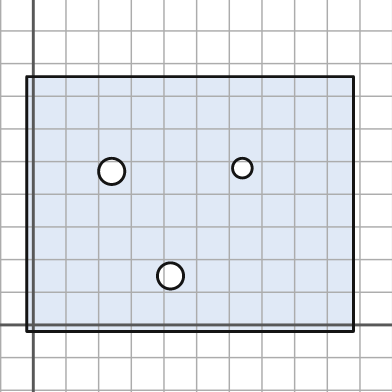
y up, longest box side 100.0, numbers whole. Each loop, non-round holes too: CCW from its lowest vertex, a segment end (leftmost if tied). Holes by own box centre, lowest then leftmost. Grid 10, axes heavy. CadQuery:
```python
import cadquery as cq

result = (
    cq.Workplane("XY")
    .moveTo(-2.0, -2.0)
    .lineTo(98.0, -2.0)
    .lineTo(98.0, 76.0)
    .lineTo(-2.0, 76.0)
    .close()
    .moveTo(42.0, 15.0)
    .circle(4.0)
    .moveTo(24.0, 47.0)
    .circle(4.0)
    .moveTo(64.0, 48.0)
    .circle(3.0)
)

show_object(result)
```